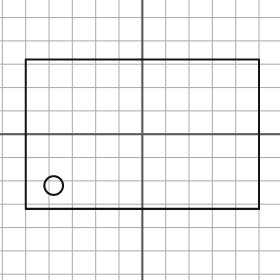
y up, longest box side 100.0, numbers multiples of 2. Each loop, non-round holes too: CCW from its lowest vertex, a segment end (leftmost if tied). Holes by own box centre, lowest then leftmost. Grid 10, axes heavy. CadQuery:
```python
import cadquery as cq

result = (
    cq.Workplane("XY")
    .moveTo(-50.0, -32.0)
    .lineTo(50.0, -32.0)
    .lineTo(50.0, 32.0)
    .lineTo(-50.0, 32.0)
    .close()
    .moveTo(-38.0, -22.0)
    .circle(4.0)
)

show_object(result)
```